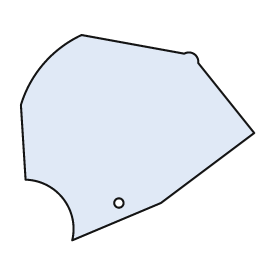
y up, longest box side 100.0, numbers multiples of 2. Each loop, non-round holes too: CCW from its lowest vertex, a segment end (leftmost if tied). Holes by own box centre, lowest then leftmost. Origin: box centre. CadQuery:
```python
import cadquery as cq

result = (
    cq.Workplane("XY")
    .moveTo(-28.0, -44.0)
    .lineTo(10.0, -28.0)
    .lineTo(50.0, 2.0)
    .lineTo(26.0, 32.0)
    .threePointArc((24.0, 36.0), (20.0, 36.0))
    .lineTo(-24.0, 44.0)
    .threePointArc((-40.0, 32.0), (-50.0, 14.0))
    .lineTo(-48.0, -18.0)
    .threePointArc((-32.0, -26.0), (-28.0, -44.0))
    .close()
    .moveTo(-8.0, -28.0)
    .circle(2.0)
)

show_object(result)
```